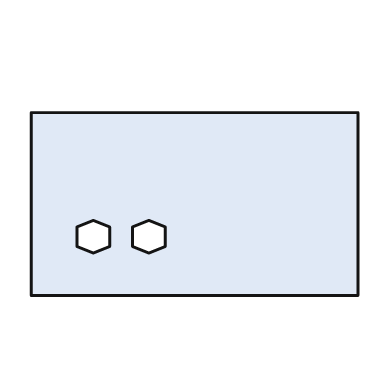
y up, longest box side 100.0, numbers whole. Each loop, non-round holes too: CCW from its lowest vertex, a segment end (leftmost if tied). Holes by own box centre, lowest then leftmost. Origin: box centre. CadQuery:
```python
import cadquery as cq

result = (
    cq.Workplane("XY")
    .moveTo(-50.0, -28.0)
    .lineTo(50.0, -28.0)
    .lineTo(50.0, 28.0)
    .lineTo(-50.0, 28.0)
    .close()
    .moveTo(-31.0, -15.0)
    .lineTo(-26.0, -13.0)
    .lineTo(-26.0, -7.0)
    .lineTo(-31.0, -5.0)
    .lineTo(-36.0, -7.0)
    .lineTo(-36.0, -13.0)
    .close()
    .moveTo(-14.0, -15.0)
    .lineTo(-9.0, -13.0)
    .lineTo(-9.0, -7.0)
    .lineTo(-14.0, -5.0)
    .lineTo(-19.0, -7.0)
    .lineTo(-19.0, -13.0)
    .close()
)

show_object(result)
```